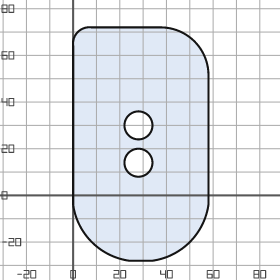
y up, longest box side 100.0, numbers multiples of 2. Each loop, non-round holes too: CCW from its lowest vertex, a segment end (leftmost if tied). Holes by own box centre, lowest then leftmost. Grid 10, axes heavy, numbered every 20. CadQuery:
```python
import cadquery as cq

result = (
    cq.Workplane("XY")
    .moveTo(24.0, -28.0)
    .lineTo(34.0, -28.0)
    .threePointArc((50.0, -20.0), (58.0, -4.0))
    .lineTo(58.0, 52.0)
    .threePointArc((52.0, 66.0), (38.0, 72.0))
    .lineTo(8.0, 72.0)
    .threePointArc((2.0, 70.0), (0.0, 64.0))
    .lineTo(0.0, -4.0)
    .threePointArc((8.0, -20.0), (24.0, -28.0))
    .close()
    .moveTo(28.0, 14.0)
    .circle(6.0)
    .moveTo(28.0, 30.0)
    .circle(6.0)
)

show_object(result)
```